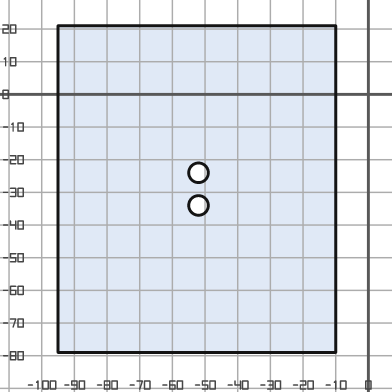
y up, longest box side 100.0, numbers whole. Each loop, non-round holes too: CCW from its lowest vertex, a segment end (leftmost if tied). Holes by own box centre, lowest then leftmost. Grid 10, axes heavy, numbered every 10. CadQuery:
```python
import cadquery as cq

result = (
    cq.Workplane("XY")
    .moveTo(-95.0, -79.0)
    .lineTo(-10.0, -79.0)
    .lineTo(-10.0, 21.0)
    .lineTo(-95.0, 21.0)
    .close()
    .moveTo(-52.0, -34.0)
    .circle(3.0)
    .moveTo(-52.0, -24.0)
    .circle(3.0)
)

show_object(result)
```